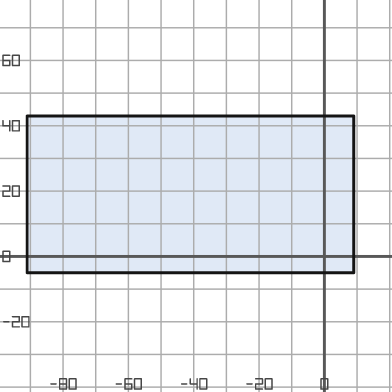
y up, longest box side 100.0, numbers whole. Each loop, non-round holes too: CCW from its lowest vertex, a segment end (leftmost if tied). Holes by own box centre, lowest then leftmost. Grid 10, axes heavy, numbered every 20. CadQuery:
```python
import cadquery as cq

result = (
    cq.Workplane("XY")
    .moveTo(-91.0, -5.0)
    .lineTo(9.0, -5.0)
    .lineTo(9.0, 43.0)
    .lineTo(-91.0, 43.0)
    .close()
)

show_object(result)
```